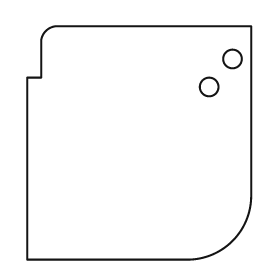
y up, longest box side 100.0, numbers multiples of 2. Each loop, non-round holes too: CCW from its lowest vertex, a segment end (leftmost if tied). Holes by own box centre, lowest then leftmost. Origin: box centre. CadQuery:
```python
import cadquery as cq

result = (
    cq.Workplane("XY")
    .moveTo(-48.0, -50.0)
    .lineTo(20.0, -50.0)
    .threePointArc((40.0, -42.0), (48.0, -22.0))
    .lineTo(48.0, 50.0)
    .lineTo(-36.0, 50.0)
    .threePointArc((-40.0, 48.0), (-42.0, 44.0))
    .lineTo(-42.0, 28.0)
    .lineTo(-48.0, 28.0)
    .close()
    .moveTo(30.0, 24.0)
    .circle(4.0)
    .moveTo(40.0, 36.0)
    .circle(4.0)
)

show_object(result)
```